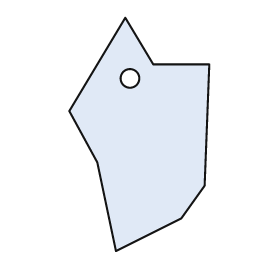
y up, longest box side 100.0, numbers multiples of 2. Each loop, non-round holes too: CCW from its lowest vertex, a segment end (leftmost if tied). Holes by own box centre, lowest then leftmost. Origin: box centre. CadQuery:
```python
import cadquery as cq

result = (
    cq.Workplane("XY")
    .moveTo(-10.0, -50.0)
    .lineTo(18.0, -36.0)
    .lineTo(28.0, -22.0)
    .lineTo(30.0, 30.0)
    .lineTo(6.0, 30.0)
    .lineTo(-6.0, 50.0)
    .lineTo(-30.0, 10.0)
    .lineTo(-18.0, -12.0)
    .close()
    .moveTo(-4.0, 24.0)
    .circle(4.0)
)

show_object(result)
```